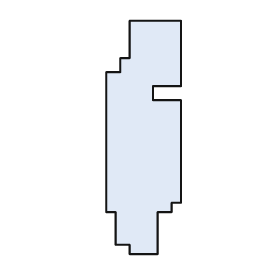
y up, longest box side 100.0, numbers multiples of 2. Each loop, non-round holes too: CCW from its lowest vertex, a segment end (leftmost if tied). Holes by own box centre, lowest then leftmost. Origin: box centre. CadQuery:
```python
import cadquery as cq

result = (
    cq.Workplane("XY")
    .moveTo(-6.0, -50.0)
    .lineTo(6.0, -50.0)
    .lineTo(6.0, -32.0)
    .lineTo(12.0, -32.0)
    .lineTo(12.0, -28.0)
    .lineTo(16.0, -28.0)
    .lineTo(16.0, 16.0)
    .lineTo(4.0, 16.0)
    .lineTo(4.0, 22.0)
    .lineTo(16.0, 22.0)
    .lineTo(16.0, 50.0)
    .lineTo(-6.0, 50.0)
    .lineTo(-6.0, 34.0)
    .lineTo(-10.0, 34.0)
    .lineTo(-10.0, 28.0)
    .lineTo(-16.0, 28.0)
    .lineTo(-16.0, -32.0)
    .lineTo(-12.0, -32.0)
    .lineTo(-12.0, -46.0)
    .lineTo(-6.0, -46.0)
    .close()
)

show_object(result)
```